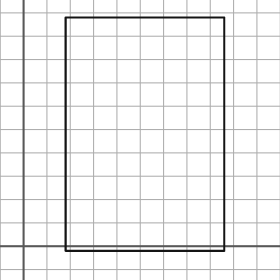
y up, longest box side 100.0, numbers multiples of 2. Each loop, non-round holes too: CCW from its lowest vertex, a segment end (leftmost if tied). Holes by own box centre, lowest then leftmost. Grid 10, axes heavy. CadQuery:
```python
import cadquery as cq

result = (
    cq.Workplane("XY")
    .moveTo(18.0, -2.0)
    .lineTo(86.0, -2.0)
    .lineTo(86.0, 98.0)
    .lineTo(18.0, 98.0)
    .close()
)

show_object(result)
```